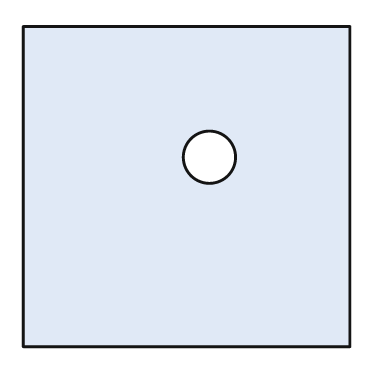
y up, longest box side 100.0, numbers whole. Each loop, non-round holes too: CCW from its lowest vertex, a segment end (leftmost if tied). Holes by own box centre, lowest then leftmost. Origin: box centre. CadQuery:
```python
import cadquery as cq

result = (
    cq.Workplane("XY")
    .moveTo(-50.0, -49.0)
    .lineTo(50.0, -49.0)
    .lineTo(50.0, 49.0)
    .lineTo(-50.0, 49.0)
    .close()
    .moveTo(7.0, 9.0)
    .circle(8.0)
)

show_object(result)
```